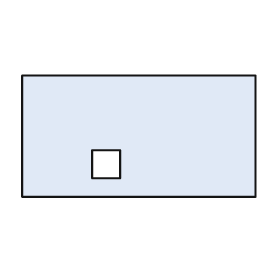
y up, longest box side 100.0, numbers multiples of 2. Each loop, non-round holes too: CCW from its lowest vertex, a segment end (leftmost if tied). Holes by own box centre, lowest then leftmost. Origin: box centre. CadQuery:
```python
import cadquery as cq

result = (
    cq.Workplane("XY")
    .moveTo(-50.0, -26.0)
    .lineTo(50.0, -26.0)
    .lineTo(50.0, 26.0)
    .lineTo(-50.0, 26.0)
    .close()
    .moveTo(-20.0, -18.0)
    .lineTo(-8.0, -18.0)
    .lineTo(-8.0, -6.0)
    .lineTo(-20.0, -6.0)
    .close()
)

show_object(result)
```